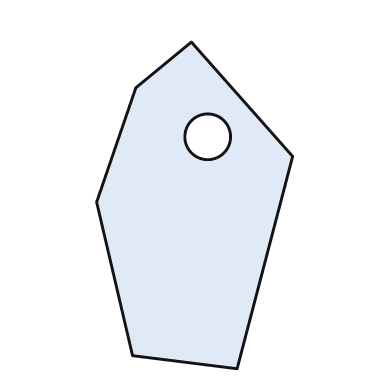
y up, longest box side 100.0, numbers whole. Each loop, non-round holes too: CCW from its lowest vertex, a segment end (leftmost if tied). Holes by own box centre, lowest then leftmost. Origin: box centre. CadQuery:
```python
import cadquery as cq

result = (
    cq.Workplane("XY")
    .moveTo(13.0, -50.0)
    .lineTo(30.0, 15.0)
    .lineTo(-1.0, 50.0)
    .lineTo(-18.0, 36.0)
    .lineTo(-30.0, 1.0)
    .lineTo(-19.0, -46.0)
    .close()
    .moveTo(4.0, 21.0)
    .circle(7.0)
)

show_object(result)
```